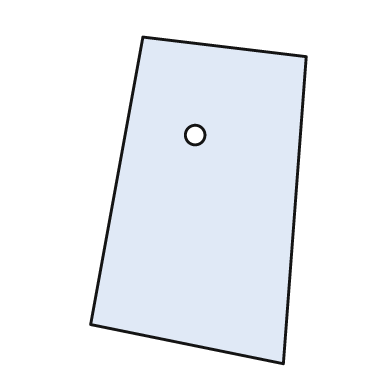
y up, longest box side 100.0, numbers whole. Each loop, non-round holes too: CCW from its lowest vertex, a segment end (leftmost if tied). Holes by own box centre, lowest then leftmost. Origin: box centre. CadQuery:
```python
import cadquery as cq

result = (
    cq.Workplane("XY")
    .moveTo(26.0, -50.0)
    .lineTo(33.0, 44.0)
    .lineTo(-17.0, 50.0)
    .lineTo(-33.0, -38.0)
    .close()
    .moveTo(-1.0, 20.0)
    .circle(3.0)
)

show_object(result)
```